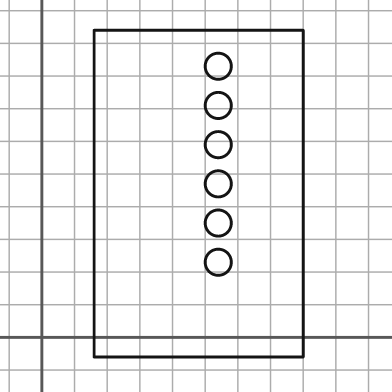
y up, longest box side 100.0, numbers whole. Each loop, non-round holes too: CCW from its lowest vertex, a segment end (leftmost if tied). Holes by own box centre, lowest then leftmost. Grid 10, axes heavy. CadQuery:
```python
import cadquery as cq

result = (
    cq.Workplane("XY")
    .moveTo(16.0, -6.0)
    .lineTo(80.0, -6.0)
    .lineTo(80.0, 94.0)
    .lineTo(16.0, 94.0)
    .close()
    .moveTo(54.0, 23.0)
    .circle(4.0)
    .moveTo(54.0, 35.0)
    .circle(4.0)
    .moveTo(54.0, 47.0)
    .circle(4.0)
    .moveTo(54.0, 59.0)
    .circle(4.0)
    .moveTo(54.0, 71.0)
    .circle(4.0)
    .moveTo(54.0, 83.0)
    .circle(4.0)
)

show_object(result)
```